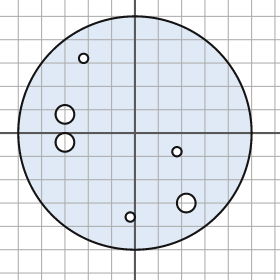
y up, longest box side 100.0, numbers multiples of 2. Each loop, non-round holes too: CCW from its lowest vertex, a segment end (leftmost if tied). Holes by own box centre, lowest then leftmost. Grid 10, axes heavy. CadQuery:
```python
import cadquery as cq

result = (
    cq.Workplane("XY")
    .moveTo(0.0, 0.0)
    .circle(50.0)
    .moveTo(-2.0, -36.0)
    .circle(2.0)
    .moveTo(22.0, -30.0)
    .circle(4.0)
    .moveTo(18.0, -8.0)
    .circle(2.0)
    .moveTo(-30.0, -4.0)
    .circle(4.0)
    .moveTo(-30.0, 8.0)
    .circle(4.0)
    .moveTo(-22.0, 32.0)
    .circle(2.0)
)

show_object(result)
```